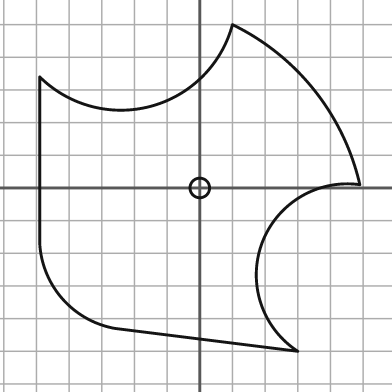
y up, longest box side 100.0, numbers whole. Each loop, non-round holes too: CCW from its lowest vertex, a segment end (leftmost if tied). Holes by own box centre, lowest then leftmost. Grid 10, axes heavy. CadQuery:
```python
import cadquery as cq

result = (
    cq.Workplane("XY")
    .moveTo(30.0, -50.0)
    .threePointArc((19.0, -17.0), (49.0, 1.0))
    .threePointArc((35.0, 30.0), (10.0, 50.0))
    .threePointArc((-15.0, 25.0), (-49.0, 34.0))
    .lineTo(-49.0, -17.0)
    .threePointArc((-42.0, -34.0), (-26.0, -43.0))
    .close()
    .moveTo(0.0, 0.0)
    .circle(3.0)
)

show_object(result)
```